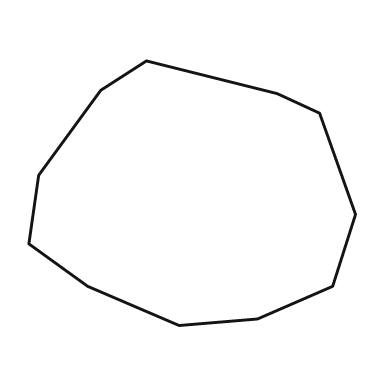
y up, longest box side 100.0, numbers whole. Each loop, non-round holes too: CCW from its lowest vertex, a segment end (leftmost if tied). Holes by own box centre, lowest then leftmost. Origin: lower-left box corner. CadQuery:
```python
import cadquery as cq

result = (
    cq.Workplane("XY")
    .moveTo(46.0, 0.0)
    .lineTo(70.0, 2.0)
    .lineTo(93.0, 12.0)
    .lineTo(100.0, 34.0)
    .lineTo(89.0, 65.0)
    .lineTo(76.0, 71.0)
    .lineTo(36.0, 81.0)
    .lineTo(22.0, 72.0)
    .lineTo(3.0, 46.0)
    .lineTo(0.0, 25.0)
    .lineTo(18.0, 12.0)
    .close()
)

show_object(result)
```